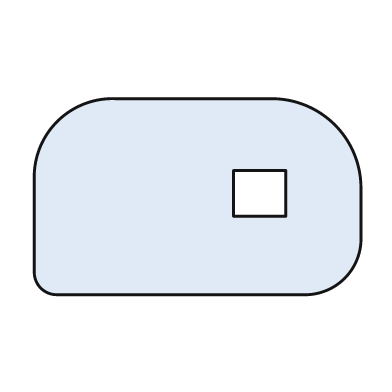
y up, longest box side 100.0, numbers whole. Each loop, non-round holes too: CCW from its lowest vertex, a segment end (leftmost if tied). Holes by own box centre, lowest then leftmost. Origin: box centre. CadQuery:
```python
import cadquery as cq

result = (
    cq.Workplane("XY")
    .moveTo(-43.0, -30.0)
    .lineTo(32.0, -30.0)
    .threePointArc((45.0, -25.0), (50.0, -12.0))
    .lineTo(50.0, 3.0)
    .threePointArc((42.0, 22.0), (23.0, 30.0))
    .lineTo(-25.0, 30.0)
    .threePointArc((-43.0, 23.0), (-50.0, 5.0))
    .lineTo(-50.0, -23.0)
    .threePointArc((-48.0, -28.0), (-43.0, -30.0))
    .close()
    .moveTo(11.0, -6.0)
    .lineTo(27.0, -6.0)
    .lineTo(27.0, 8.0)
    .lineTo(11.0, 8.0)
    .close()
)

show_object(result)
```